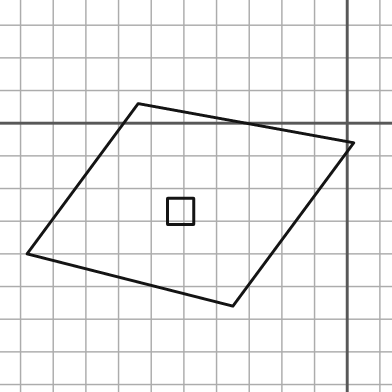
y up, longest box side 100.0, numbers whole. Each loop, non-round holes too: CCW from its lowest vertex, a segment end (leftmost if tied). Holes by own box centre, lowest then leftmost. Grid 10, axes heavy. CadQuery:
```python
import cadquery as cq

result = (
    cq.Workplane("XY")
    .moveTo(-35.0, -56.0)
    .lineTo(2.0, -6.0)
    .lineTo(-64.0, 6.0)
    .lineTo(-98.0, -40.0)
    .close()
    .moveTo(-55.0, -31.0)
    .lineTo(-47.0, -31.0)
    .lineTo(-47.0, -23.0)
    .lineTo(-55.0, -23.0)
    .close()
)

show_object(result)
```